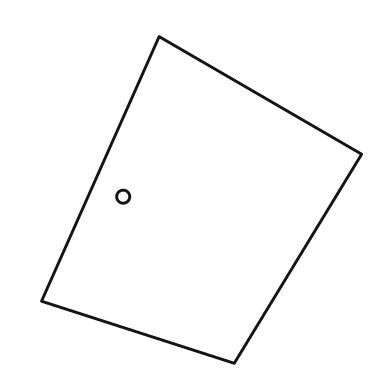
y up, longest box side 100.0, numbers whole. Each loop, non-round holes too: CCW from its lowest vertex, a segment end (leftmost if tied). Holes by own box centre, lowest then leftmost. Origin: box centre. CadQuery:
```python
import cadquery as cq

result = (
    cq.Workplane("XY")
    .moveTo(10.0, -50.0)
    .lineTo(49.0, 14.0)
    .lineTo(-13.0, 50.0)
    .lineTo(-49.0, -31.0)
    .close()
    .moveTo(-24.0, 1.0)
    .circle(2.0)
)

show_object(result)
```